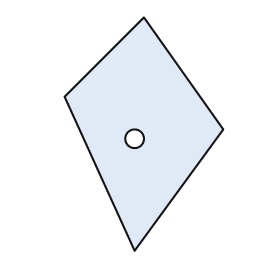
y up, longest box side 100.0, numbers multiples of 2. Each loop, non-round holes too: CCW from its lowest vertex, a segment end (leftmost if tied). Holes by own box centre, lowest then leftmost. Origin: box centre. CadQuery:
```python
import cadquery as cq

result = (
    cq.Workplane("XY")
    .moveTo(-4.0, -50.0)
    .lineTo(34.0, 2.0)
    .lineTo(0.0, 50.0)
    .lineTo(-34.0, 16.0)
    .close()
    .moveTo(-4.0, -2.0)
    .circle(4.0)
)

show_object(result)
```